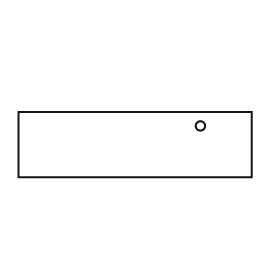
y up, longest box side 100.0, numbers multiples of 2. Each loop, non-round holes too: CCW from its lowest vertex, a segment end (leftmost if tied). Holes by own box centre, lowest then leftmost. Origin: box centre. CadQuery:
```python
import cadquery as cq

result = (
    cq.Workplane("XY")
    .moveTo(-50.0, -14.0)
    .lineTo(50.0, -14.0)
    .lineTo(50.0, 14.0)
    .lineTo(-50.0, 14.0)
    .close()
    .moveTo(28.0, 8.0)
    .circle(2.0)
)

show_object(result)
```